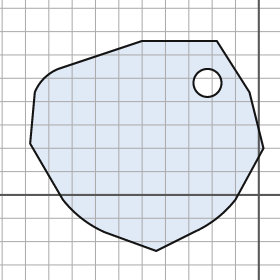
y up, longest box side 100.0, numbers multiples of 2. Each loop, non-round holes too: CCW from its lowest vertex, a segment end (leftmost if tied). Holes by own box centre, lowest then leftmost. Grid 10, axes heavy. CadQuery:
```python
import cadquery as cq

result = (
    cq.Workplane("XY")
    .moveTo(-44.0, -24.0)
    .lineTo(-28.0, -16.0)
    .threePointArc((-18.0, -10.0), (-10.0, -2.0))
    .lineTo(2.0, 20.0)
    .lineTo(-4.0, 44.0)
    .lineTo(-18.0, 66.0)
    .lineTo(-50.0, 66.0)
    .lineTo(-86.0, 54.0)
    .threePointArc((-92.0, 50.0), (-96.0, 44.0))
    .lineTo(-98.0, 22.0)
    .lineTo(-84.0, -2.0)
    .threePointArc((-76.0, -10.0), (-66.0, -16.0))
    .close()
    .moveTo(-22.0, 48.0)
    .circle(6.0)
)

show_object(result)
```